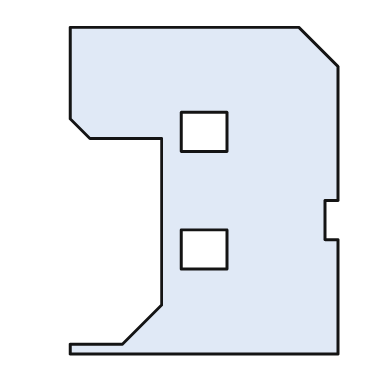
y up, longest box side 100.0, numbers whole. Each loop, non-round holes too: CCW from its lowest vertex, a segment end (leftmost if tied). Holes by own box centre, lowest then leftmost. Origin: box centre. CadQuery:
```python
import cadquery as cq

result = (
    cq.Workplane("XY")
    .moveTo(-41.0, -50.0)
    .lineTo(41.0, -50.0)
    .lineTo(41.0, -15.0)
    .lineTo(37.0, -15.0)
    .lineTo(37.0, -3.0)
    .lineTo(41.0, -3.0)
    .lineTo(41.0, 38.0)
    .lineTo(29.0, 50.0)
    .lineTo(-41.0, 50.0)
    .lineTo(-41.0, 22.0)
    .lineTo(-35.0, 16.0)
    .lineTo(-13.0, 16.0)
    .lineTo(-13.0, -35.0)
    .lineTo(-25.0, -47.0)
    .lineTo(-41.0, -47.0)
    .close()
    .moveTo(-7.0, -24.0)
    .lineTo(7.0, -24.0)
    .lineTo(7.0, -12.0)
    .lineTo(-7.0, -12.0)
    .close()
    .moveTo(-7.0, 12.0)
    .lineTo(7.0, 12.0)
    .lineTo(7.0, 24.0)
    .lineTo(-7.0, 24.0)
    .close()
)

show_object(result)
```